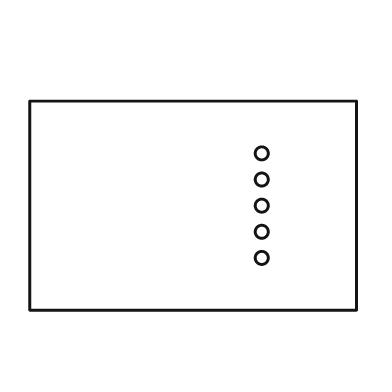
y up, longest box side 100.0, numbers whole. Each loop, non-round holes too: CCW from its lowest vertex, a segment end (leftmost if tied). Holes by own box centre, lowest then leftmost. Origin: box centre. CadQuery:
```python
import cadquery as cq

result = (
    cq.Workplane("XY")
    .moveTo(-50.0, -32.0)
    .lineTo(50.0, -32.0)
    .lineTo(50.0, 32.0)
    .lineTo(-50.0, 32.0)
    .close()
    .moveTo(21.0, -16.0)
    .circle(2.0)
    .moveTo(21.0, -8.0)
    .circle(2.0)
    .moveTo(21.0, 0.0)
    .circle(2.0)
    .moveTo(21.0, 8.0)
    .circle(2.0)
    .moveTo(21.0, 16.0)
    .circle(2.0)
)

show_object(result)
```